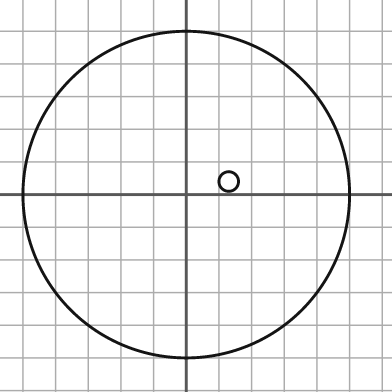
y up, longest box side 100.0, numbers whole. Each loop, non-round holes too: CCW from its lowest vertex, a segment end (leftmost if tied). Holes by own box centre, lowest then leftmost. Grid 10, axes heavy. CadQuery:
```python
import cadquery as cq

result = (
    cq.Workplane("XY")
    .moveTo(0.0, 0.0)
    .circle(50.0)
    .moveTo(13.0, 4.0)
    .circle(3.0)
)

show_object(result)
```